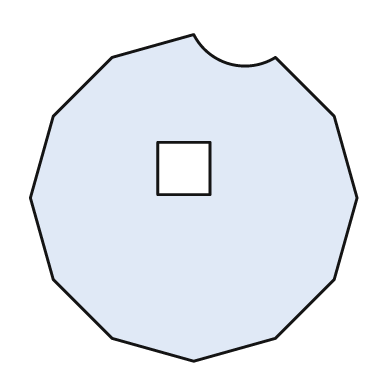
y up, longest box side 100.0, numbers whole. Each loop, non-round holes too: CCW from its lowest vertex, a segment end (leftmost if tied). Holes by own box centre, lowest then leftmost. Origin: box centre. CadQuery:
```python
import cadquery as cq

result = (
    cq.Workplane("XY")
    .moveTo(0.0, -50.0)
    .lineTo(25.0, -43.0)
    .lineTo(43.0, -25.0)
    .lineTo(50.0, 0.0)
    .lineTo(43.0, 25.0)
    .lineTo(25.0, 43.0)
    .threePointArc((11.0, 41.0), (0.0, 50.0))
    .lineTo(-25.0, 43.0)
    .lineTo(-43.0, 25.0)
    .lineTo(-50.0, 0.0)
    .lineTo(-43.0, -25.0)
    .lineTo(-25.0, -43.0)
    .close()
    .moveTo(-11.0, 1.0)
    .lineTo(5.0, 1.0)
    .lineTo(5.0, 17.0)
    .lineTo(-11.0, 17.0)
    .close()
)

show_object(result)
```